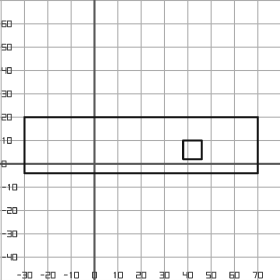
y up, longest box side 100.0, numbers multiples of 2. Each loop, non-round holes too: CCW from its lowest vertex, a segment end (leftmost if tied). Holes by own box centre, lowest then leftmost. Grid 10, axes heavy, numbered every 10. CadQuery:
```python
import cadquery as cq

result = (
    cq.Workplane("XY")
    .moveTo(-30.0, -4.0)
    .lineTo(70.0, -4.0)
    .lineTo(70.0, 20.0)
    .lineTo(-30.0, 20.0)
    .close()
    .moveTo(38.0, 2.0)
    .lineTo(46.0, 2.0)
    .lineTo(46.0, 10.0)
    .lineTo(38.0, 10.0)
    .close()
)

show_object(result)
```